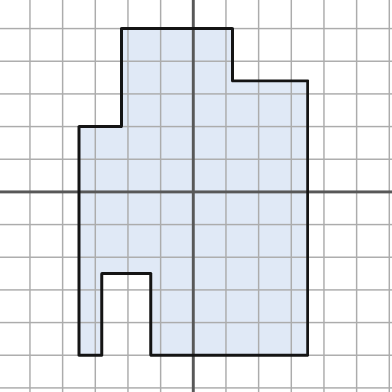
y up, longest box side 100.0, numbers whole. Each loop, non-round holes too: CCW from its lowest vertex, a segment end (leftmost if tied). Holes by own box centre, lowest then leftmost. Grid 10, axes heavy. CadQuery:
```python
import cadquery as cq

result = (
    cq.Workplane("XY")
    .moveTo(-35.0, -50.0)
    .lineTo(-28.0, -50.0)
    .lineTo(-28.0, -25.0)
    .lineTo(-13.0, -25.0)
    .lineTo(-13.0, -50.0)
    .lineTo(35.0, -50.0)
    .lineTo(35.0, 34.0)
    .lineTo(12.0, 34.0)
    .lineTo(12.0, 50.0)
    .lineTo(-22.0, 50.0)
    .lineTo(-22.0, 20.0)
    .lineTo(-35.0, 20.0)
    .close()
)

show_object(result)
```